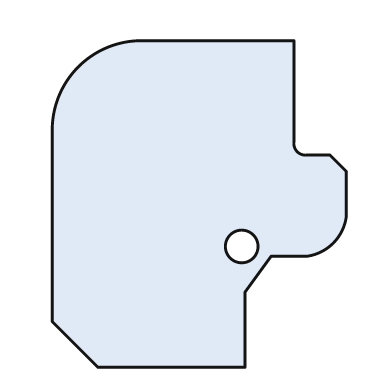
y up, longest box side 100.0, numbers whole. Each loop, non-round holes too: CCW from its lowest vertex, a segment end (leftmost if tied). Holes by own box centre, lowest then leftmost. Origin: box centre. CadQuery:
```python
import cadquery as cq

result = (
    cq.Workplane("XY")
    .moveTo(-31.0, -50.0)
    .lineTo(14.0, -50.0)
    .lineTo(14.0, -27.0)
    .lineTo(22.0, -16.0)
    .lineTo(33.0, -16.0)
    .threePointArc((41.0, -12.0), (45.0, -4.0))
    .lineTo(45.0, 10.0)
    .lineTo(40.0, 15.0)
    .lineTo(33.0, 15.0)
    .threePointArc((30.0, 16.0), (29.0, 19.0))
    .lineTo(29.0, 50.0)
    .lineTo(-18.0, 50.0)
    .threePointArc((-37.0, 42.0), (-45.0, 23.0))
    .lineTo(-45.0, -36.0)
    .close()
    .moveTo(13.0, -13.0)
    .circle(5.0)
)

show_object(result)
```